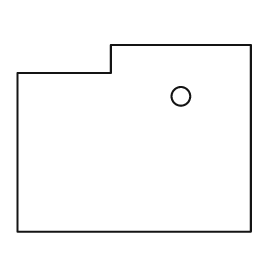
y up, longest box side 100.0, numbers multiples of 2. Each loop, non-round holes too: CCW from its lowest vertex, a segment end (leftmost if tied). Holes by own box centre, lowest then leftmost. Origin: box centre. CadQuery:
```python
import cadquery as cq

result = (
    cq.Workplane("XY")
    .moveTo(-50.0, -40.0)
    .lineTo(50.0, -40.0)
    .lineTo(50.0, 40.0)
    .lineTo(-10.0, 40.0)
    .lineTo(-10.0, 28.0)
    .lineTo(-50.0, 28.0)
    .close()
    .moveTo(20.0, 18.0)
    .circle(4.0)
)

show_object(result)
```